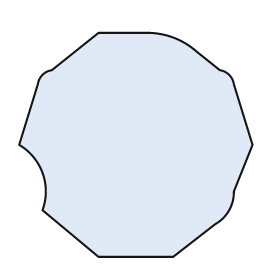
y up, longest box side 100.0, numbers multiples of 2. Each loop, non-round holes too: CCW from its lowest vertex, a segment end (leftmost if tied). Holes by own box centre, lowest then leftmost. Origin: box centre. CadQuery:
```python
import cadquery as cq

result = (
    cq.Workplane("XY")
    .moveTo(-16.0, -48.0)
    .lineTo(16.0, -48.0)
    .lineTo(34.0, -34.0)
    .threePointArc((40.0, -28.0), (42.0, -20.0))
    .lineTo(50.0, 0.0)
    .lineTo(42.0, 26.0)
    .threePointArc((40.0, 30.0), (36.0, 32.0))
    .lineTo(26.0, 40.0)
    .threePointArc((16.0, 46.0), (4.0, 48.0))
    .lineTo(-16.0, 48.0)
    .lineTo(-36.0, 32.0)
    .threePointArc((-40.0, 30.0), (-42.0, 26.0))
    .lineTo(-50.0, 0.0)
    .threePointArc((-40.0, -12.0), (-40.0, -28.0))
    .close()
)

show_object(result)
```